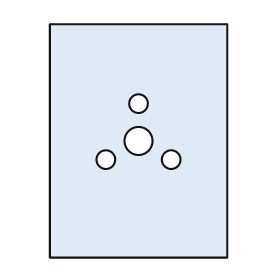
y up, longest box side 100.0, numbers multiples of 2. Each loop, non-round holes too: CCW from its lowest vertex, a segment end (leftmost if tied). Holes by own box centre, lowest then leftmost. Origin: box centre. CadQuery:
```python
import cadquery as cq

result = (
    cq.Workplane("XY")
    .moveTo(-38.0, -50.0)
    .lineTo(38.0, -50.0)
    .lineTo(38.0, 50.0)
    .lineTo(-38.0, 50.0)
    .close()
    .moveTo(-14.0, -8.0)
    .circle(4.0)
    .moveTo(14.0, -8.0)
    .circle(4.0)
    .moveTo(0.0, 0.0)
    .circle(6.0)
    .moveTo(0.0, 16.0)
    .circle(4.0)
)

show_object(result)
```